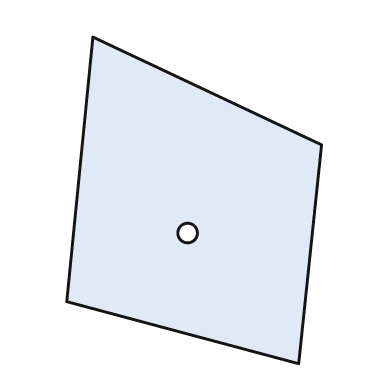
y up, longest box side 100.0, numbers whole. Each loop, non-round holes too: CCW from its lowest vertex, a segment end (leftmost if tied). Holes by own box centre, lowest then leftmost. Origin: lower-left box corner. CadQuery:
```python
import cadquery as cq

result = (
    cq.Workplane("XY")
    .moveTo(71.0, 0.0)
    .lineTo(78.0, 67.0)
    .lineTo(8.0, 100.0)
    .lineTo(0.0, 19.0)
    .close()
    .moveTo(37.0, 40.0)
    .circle(3.0)
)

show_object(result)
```